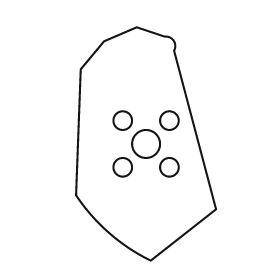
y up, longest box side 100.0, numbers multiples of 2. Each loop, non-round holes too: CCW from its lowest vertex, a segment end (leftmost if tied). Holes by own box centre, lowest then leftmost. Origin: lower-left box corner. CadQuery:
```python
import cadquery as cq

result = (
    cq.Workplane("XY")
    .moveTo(32.0, 0.0)
    .lineTo(60.0, 22.0)
    .lineTo(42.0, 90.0)
    .threePointArc((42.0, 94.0), (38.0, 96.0))
    .lineTo(26.0, 100.0)
    .lineTo(12.0, 94.0)
    .lineTo(2.0, 82.0)
    .lineTo(0.0, 28.0)
    .threePointArc((14.0, 12.0), (32.0, 0.0))
    .close()
    .moveTo(20.0, 40.0)
    .circle(4.0)
    .moveTo(40.0, 40.0)
    .circle(4.0)
    .moveTo(30.0, 50.0)
    .circle(6.0)
    .moveTo(20.0, 60.0)
    .circle(4.0)
    .moveTo(40.0, 60.0)
    .circle(4.0)
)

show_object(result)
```